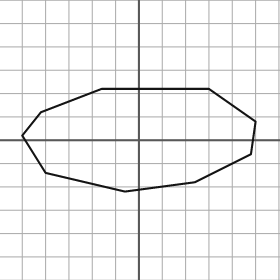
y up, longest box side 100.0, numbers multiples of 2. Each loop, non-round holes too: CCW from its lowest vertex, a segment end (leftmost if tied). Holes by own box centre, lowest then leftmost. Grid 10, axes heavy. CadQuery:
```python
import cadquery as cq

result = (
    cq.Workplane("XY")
    .moveTo(-6.0, -22.0)
    .lineTo(24.0, -18.0)
    .lineTo(48.0, -6.0)
    .lineTo(50.0, 8.0)
    .lineTo(30.0, 22.0)
    .lineTo(-16.0, 22.0)
    .lineTo(-42.0, 12.0)
    .lineTo(-50.0, 2.0)
    .lineTo(-40.0, -14.0)
    .close()
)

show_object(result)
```